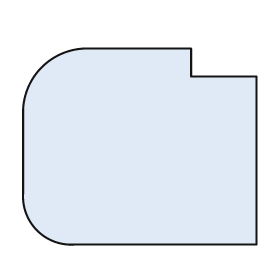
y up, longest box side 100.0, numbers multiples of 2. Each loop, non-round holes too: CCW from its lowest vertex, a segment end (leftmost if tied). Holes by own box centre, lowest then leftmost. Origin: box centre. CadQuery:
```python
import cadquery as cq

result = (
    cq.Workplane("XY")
    .moveTo(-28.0, -42.0)
    .lineTo(50.0, -42.0)
    .lineTo(50.0, 30.0)
    .lineTo(22.0, 30.0)
    .lineTo(22.0, 42.0)
    .lineTo(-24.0, 42.0)
    .threePointArc((-42.0, 34.0), (-50.0, 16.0))
    .lineTo(-50.0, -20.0)
    .threePointArc((-44.0, -36.0), (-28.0, -42.0))
    .close()
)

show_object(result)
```